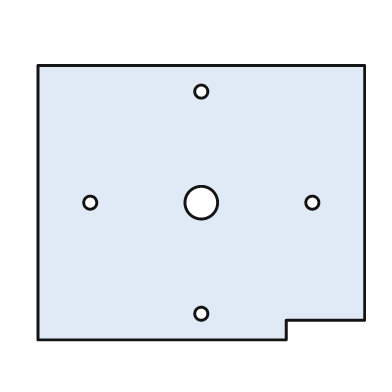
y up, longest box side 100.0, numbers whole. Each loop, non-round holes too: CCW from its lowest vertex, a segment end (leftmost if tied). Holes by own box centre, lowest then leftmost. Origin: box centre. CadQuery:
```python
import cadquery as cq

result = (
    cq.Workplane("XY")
    .moveTo(-50.0, -42.0)
    .lineTo(26.0, -42.0)
    .lineTo(26.0, -36.0)
    .lineTo(50.0, -36.0)
    .lineTo(50.0, 42.0)
    .lineTo(-50.0, 42.0)
    .close()
    .moveTo(0.0, -34.0)
    .circle(2.0)
    .moveTo(-34.0, 0.0)
    .circle(2.0)
    .moveTo(0.0, 0.0)
    .circle(5.0)
    .moveTo(34.0, 0.0)
    .circle(2.0)
    .moveTo(0.0, 34.0)
    .circle(2.0)
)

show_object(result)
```